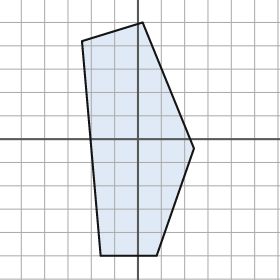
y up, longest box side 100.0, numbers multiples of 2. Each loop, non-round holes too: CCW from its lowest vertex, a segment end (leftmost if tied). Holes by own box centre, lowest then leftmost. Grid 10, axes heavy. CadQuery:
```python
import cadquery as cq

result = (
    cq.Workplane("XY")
    .moveTo(-16.0, -50.0)
    .lineTo(8.0, -50.0)
    .lineTo(24.0, -4.0)
    .lineTo(2.0, 50.0)
    .lineTo(-24.0, 42.0)
    .close()
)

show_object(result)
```